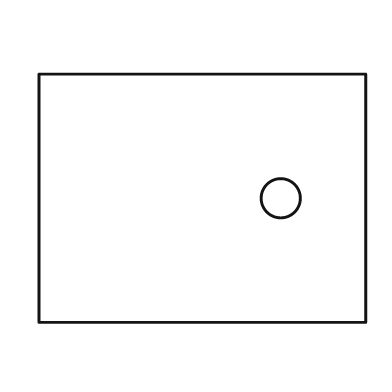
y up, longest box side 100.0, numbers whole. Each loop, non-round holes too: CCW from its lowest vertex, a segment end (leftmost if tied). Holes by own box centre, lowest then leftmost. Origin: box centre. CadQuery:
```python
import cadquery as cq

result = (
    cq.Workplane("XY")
    .moveTo(-50.0, -38.0)
    .lineTo(50.0, -38.0)
    .lineTo(50.0, 38.0)
    .lineTo(-50.0, 38.0)
    .close()
    .moveTo(24.0, 0.0)
    .circle(6.0)
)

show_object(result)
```